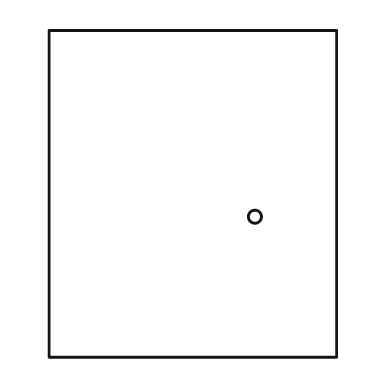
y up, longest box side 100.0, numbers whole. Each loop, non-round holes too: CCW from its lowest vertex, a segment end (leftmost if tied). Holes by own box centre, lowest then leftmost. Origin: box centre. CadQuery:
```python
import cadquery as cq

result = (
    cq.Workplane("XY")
    .moveTo(-44.0, -50.0)
    .lineTo(44.0, -50.0)
    .lineTo(44.0, 50.0)
    .lineTo(-44.0, 50.0)
    .close()
    .moveTo(19.0, -7.0)
    .circle(2.0)
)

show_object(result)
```